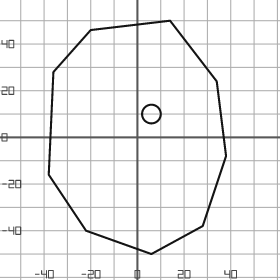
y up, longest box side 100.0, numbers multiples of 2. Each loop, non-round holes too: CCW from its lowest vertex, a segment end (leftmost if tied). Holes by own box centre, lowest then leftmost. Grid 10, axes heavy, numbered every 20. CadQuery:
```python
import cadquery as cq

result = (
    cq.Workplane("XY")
    .moveTo(6.0, -50.0)
    .lineTo(28.0, -38.0)
    .lineTo(38.0, -8.0)
    .lineTo(34.0, 24.0)
    .lineTo(14.0, 50.0)
    .lineTo(-20.0, 46.0)
    .lineTo(-36.0, 28.0)
    .lineTo(-38.0, -16.0)
    .lineTo(-22.0, -40.0)
    .close()
    .moveTo(6.0, 10.0)
    .circle(4.0)
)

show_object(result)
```